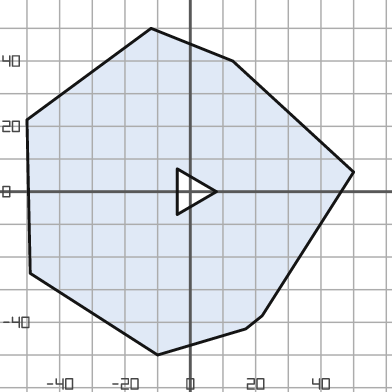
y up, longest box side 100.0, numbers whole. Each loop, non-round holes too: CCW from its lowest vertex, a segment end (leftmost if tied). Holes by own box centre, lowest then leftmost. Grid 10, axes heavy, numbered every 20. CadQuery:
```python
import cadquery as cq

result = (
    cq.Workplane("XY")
    .moveTo(-10.0, -50.0)
    .lineTo(17.0, -42.0)
    .lineTo(22.0, -38.0)
    .lineTo(50.0, 6.0)
    .lineTo(13.0, 40.0)
    .lineTo(-12.0, 50.0)
    .lineTo(-50.0, 22.0)
    .lineTo(-49.0, -25.0)
    .close()
    .moveTo(-4.0, -7.0)
    .lineTo(8.0, 0.0)
    .lineTo(-4.0, 7.0)
    .close()
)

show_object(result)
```